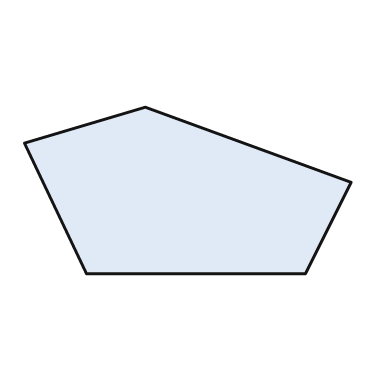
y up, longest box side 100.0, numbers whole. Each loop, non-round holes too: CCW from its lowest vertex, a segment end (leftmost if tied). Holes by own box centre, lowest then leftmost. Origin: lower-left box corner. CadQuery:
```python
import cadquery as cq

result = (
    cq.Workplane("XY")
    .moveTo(19.0, 0.0)
    .lineTo(86.0, 0.0)
    .lineTo(100.0, 28.0)
    .lineTo(37.0, 51.0)
    .lineTo(0.0, 40.0)
    .close()
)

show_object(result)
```